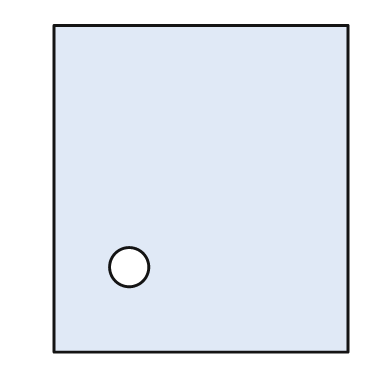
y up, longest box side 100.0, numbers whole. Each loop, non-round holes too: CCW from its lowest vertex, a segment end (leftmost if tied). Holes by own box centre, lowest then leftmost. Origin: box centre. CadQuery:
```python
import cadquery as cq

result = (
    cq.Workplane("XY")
    .moveTo(-45.0, -50.0)
    .lineTo(45.0, -50.0)
    .lineTo(45.0, 50.0)
    .lineTo(-45.0, 50.0)
    .close()
    .moveTo(-22.0, -24.0)
    .circle(6.0)
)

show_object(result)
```